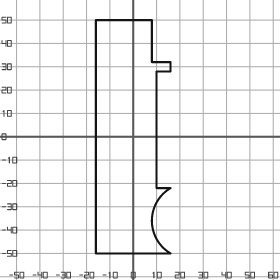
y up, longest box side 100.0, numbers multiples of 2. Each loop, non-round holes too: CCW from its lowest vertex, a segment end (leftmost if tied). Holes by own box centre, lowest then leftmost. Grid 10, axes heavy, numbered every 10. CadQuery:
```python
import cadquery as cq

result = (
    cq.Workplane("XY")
    .moveTo(-16.0, -50.0)
    .lineTo(16.0, -50.0)
    .threePointArc((8.0, -36.0), (16.0, -22.0))
    .lineTo(10.0, -22.0)
    .lineTo(10.0, 28.0)
    .lineTo(16.0, 28.0)
    .lineTo(16.0, 32.0)
    .lineTo(8.0, 32.0)
    .lineTo(8.0, 50.0)
    .lineTo(-16.0, 50.0)
    .close()
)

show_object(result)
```